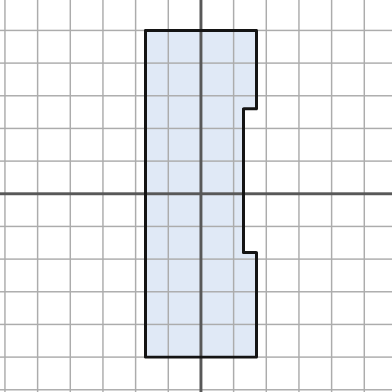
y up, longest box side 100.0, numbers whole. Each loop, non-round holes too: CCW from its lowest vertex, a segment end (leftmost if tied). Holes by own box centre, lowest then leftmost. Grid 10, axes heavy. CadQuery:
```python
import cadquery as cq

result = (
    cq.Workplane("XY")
    .moveTo(-17.0, -50.0)
    .lineTo(17.0, -50.0)
    .lineTo(17.0, -18.0)
    .lineTo(13.0, -18.0)
    .lineTo(13.0, 26.0)
    .lineTo(17.0, 26.0)
    .lineTo(17.0, 50.0)
    .lineTo(-17.0, 50.0)
    .close()
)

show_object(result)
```